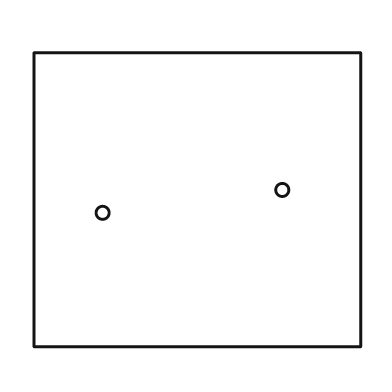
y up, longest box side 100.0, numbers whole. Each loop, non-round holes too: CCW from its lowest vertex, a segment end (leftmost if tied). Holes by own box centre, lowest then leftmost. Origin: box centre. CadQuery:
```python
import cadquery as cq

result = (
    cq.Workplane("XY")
    .moveTo(-50.0, -45.0)
    .lineTo(50.0, -45.0)
    .lineTo(50.0, 45.0)
    .lineTo(-50.0, 45.0)
    .close()
    .moveTo(-29.0, -4.0)
    .circle(2.0)
    .moveTo(26.0, 3.0)
    .circle(2.0)
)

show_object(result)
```